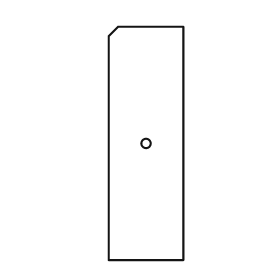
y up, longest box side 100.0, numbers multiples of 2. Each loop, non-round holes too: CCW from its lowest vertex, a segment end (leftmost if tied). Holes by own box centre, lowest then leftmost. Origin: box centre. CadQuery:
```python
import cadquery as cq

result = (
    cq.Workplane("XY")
    .moveTo(-16.0, -50.0)
    .lineTo(16.0, -50.0)
    .lineTo(16.0, 50.0)
    .lineTo(-12.0, 50.0)
    .lineTo(-16.0, 46.0)
    .close()
    .moveTo(0.0, 0.0)
    .circle(2.0)
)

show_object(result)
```